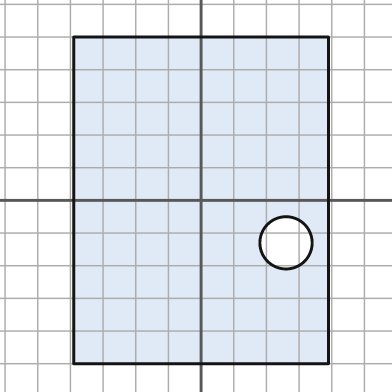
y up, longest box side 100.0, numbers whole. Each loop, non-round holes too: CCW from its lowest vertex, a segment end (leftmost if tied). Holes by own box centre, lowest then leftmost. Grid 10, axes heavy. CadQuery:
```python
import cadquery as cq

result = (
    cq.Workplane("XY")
    .moveTo(-39.0, -50.0)
    .lineTo(39.0, -50.0)
    .lineTo(39.0, 50.0)
    .lineTo(-39.0, 50.0)
    .close()
    .moveTo(26.0, -13.0)
    .circle(8.0)
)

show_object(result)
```